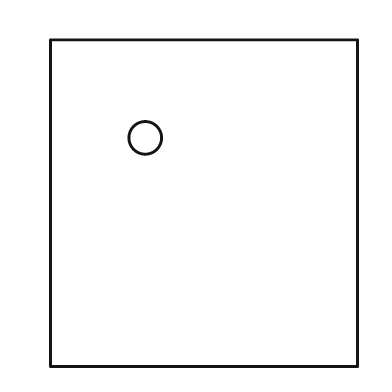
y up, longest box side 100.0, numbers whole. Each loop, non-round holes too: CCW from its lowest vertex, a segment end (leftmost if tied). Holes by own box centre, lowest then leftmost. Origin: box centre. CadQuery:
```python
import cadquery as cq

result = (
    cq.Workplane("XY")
    .moveTo(-47.0, -50.0)
    .lineTo(47.0, -50.0)
    .lineTo(47.0, 50.0)
    .lineTo(-47.0, 50.0)
    .close()
    .moveTo(-18.0, 20.0)
    .circle(5.0)
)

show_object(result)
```